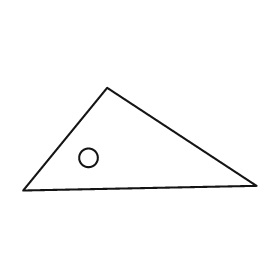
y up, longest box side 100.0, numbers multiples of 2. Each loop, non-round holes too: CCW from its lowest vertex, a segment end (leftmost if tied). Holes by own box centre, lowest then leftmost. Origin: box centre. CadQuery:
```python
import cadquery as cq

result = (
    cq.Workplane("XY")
    .moveTo(-50.0, -22.0)
    .lineTo(50.0, -20.0)
    .lineTo(-14.0, 22.0)
    .close()
    .moveTo(-22.0, -8.0)
    .circle(4.0)
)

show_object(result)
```